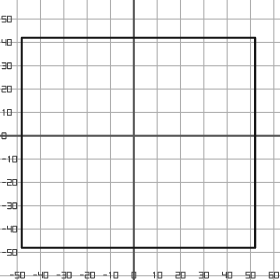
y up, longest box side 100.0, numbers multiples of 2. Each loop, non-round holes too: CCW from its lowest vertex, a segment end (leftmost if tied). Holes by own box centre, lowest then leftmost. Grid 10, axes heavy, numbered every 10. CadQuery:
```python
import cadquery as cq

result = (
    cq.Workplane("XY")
    .moveTo(-48.0, -48.0)
    .lineTo(52.0, -48.0)
    .lineTo(52.0, 42.0)
    .lineTo(-48.0, 42.0)
    .close()
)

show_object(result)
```